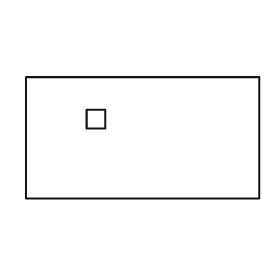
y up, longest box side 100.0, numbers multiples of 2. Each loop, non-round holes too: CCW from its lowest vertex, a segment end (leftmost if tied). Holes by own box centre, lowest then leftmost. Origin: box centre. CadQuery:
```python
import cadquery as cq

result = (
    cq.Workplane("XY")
    .moveTo(-50.0, -26.0)
    .lineTo(50.0, -26.0)
    .lineTo(50.0, 26.0)
    .lineTo(-50.0, 26.0)
    .close()
    .moveTo(-24.0, 4.0)
    .lineTo(-16.0, 4.0)
    .lineTo(-16.0, 12.0)
    .lineTo(-24.0, 12.0)
    .close()
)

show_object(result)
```